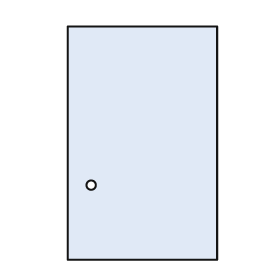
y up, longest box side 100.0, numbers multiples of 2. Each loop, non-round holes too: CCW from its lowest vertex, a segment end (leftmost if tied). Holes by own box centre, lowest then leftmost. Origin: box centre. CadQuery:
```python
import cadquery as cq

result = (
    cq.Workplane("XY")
    .moveTo(-32.0, -50.0)
    .lineTo(32.0, -50.0)
    .lineTo(32.0, 50.0)
    .lineTo(-32.0, 50.0)
    .close()
    .moveTo(-22.0, -18.0)
    .circle(2.0)
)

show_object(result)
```